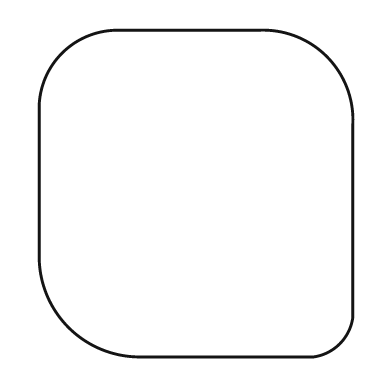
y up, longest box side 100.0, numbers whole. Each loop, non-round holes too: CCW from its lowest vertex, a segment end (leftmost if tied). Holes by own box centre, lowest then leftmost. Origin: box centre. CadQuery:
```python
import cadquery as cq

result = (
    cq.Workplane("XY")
    .moveTo(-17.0, -50.0)
    .lineTo(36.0, -50.0)
    .threePointArc((44.0, -46.0), (48.0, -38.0))
    .lineTo(48.0, 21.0)
    .threePointArc((40.0, 42.0), (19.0, 50.0))
    .lineTo(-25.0, 50.0)
    .threePointArc((-41.0, 43.0), (-48.0, 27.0))
    .lineTo(-48.0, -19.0)
    .threePointArc((-39.0, -41.0), (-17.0, -50.0))
    .close()
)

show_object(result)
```